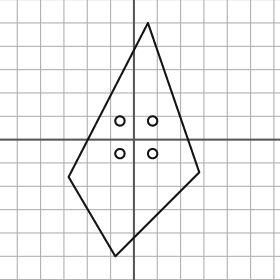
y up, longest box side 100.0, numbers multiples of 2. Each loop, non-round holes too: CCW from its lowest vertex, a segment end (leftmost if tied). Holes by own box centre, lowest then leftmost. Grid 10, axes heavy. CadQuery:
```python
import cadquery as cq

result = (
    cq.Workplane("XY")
    .moveTo(-8.0, -50.0)
    .lineTo(28.0, -14.0)
    .lineTo(6.0, 50.0)
    .lineTo(-28.0, -16.0)
    .close()
    .moveTo(-6.0, -6.0)
    .circle(2.0)
    .moveTo(8.0, -6.0)
    .circle(2.0)
    .moveTo(-6.0, 8.0)
    .circle(2.0)
    .moveTo(8.0, 8.0)
    .circle(2.0)
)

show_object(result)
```